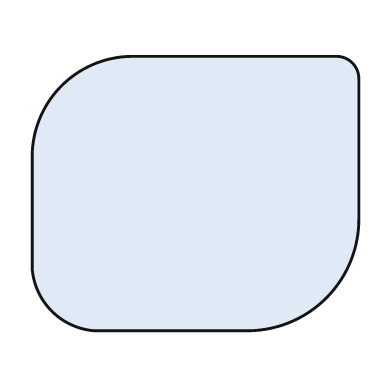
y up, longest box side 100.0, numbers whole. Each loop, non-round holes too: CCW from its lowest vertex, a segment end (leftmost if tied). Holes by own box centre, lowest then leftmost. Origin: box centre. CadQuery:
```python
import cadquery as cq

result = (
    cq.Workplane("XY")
    .moveTo(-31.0, -42.0)
    .lineTo(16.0, -42.0)
    .threePointArc((40.0, -32.0), (50.0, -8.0))
    .lineTo(50.0, 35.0)
    .threePointArc((48.0, 40.0), (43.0, 42.0))
    .lineTo(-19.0, 42.0)
    .threePointArc((-41.0, 33.0), (-50.0, 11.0))
    .lineTo(-50.0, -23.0)
    .threePointArc((-44.0, -36.0), (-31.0, -42.0))
    .close()
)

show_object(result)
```